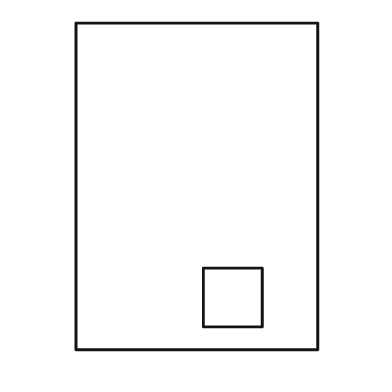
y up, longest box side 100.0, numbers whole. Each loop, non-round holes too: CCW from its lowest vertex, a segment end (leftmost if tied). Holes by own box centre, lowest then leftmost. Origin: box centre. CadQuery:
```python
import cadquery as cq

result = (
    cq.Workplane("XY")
    .moveTo(-37.0, -50.0)
    .lineTo(37.0, -50.0)
    .lineTo(37.0, 50.0)
    .lineTo(-37.0, 50.0)
    .close()
    .moveTo(2.0, -43.0)
    .lineTo(20.0, -43.0)
    .lineTo(20.0, -25.0)
    .lineTo(2.0, -25.0)
    .close()
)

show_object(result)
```